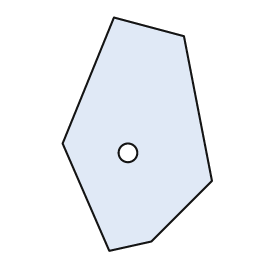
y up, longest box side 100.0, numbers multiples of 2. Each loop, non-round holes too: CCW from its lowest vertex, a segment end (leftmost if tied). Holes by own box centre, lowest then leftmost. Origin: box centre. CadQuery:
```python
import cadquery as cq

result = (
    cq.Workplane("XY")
    .moveTo(-12.0, -50.0)
    .lineTo(6.0, -46.0)
    .lineTo(32.0, -20.0)
    .lineTo(20.0, 42.0)
    .lineTo(-10.0, 50.0)
    .lineTo(-32.0, -4.0)
    .close()
    .moveTo(-4.0, -8.0)
    .circle(4.0)
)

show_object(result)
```